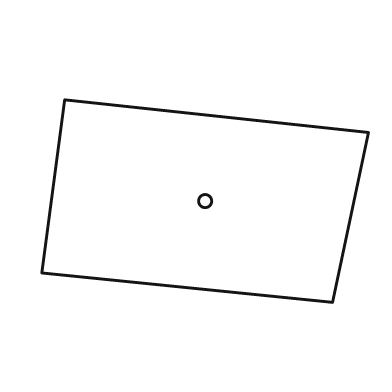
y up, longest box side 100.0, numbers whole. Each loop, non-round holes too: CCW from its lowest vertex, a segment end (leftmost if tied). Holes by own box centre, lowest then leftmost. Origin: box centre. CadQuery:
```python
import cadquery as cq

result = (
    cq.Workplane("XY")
    .moveTo(39.0, -31.0)
    .lineTo(50.0, 21.0)
    .lineTo(-43.0, 31.0)
    .lineTo(-50.0, -22.0)
    .close()
    .moveTo(0.0, 0.0)
    .circle(2.0)
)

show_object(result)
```